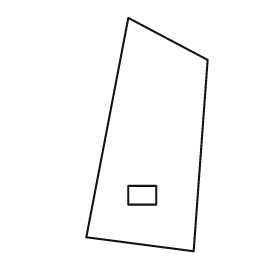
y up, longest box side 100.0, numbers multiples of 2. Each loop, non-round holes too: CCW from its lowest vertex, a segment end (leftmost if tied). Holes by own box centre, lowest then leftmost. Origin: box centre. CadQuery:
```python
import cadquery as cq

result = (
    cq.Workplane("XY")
    .moveTo(20.0, -50.0)
    .lineTo(26.0, 32.0)
    .lineTo(-8.0, 50.0)
    .lineTo(-26.0, -44.0)
    .close()
    .moveTo(-8.0, -30.0)
    .lineTo(4.0, -30.0)
    .lineTo(4.0, -22.0)
    .lineTo(-8.0, -22.0)
    .close()
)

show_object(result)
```